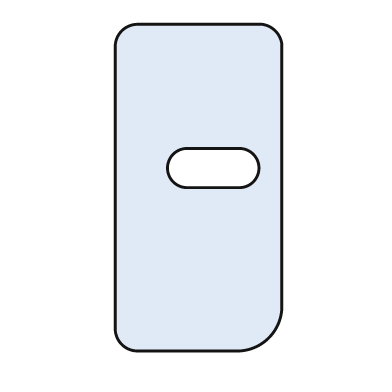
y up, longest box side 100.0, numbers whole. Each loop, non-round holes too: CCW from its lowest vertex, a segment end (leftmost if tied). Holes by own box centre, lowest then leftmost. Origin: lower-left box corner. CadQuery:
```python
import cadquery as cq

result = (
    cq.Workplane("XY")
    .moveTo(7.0, 0.0)
    .lineTo(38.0, 0.0)
    .threePointArc((47.0, 4.0), (51.0, 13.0))
    .lineTo(51.0, 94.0)
    .threePointArc((49.0, 98.0), (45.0, 100.0))
    .lineTo(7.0, 100.0)
    .threePointArc((2.0, 98.0), (0.0, 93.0))
    .lineTo(0.0, 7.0)
    .threePointArc((2.0, 2.0), (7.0, 0.0))
    .close()
    .moveTo(22.0, 50.0)
    .lineTo(38.0, 50.0)
    .threePointArc((44.0, 56.0), (38.0, 62.0))
    .lineTo(22.0, 62.0)
    .threePointArc((16.0, 56.0), (22.0, 50.0))
    .close()
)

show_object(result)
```